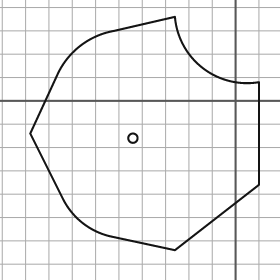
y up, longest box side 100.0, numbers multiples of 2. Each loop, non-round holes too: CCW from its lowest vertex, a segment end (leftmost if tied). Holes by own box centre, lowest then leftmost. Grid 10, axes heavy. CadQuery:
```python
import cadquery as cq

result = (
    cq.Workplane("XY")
    .moveTo(-26.0, -64.0)
    .lineTo(10.0, -36.0)
    .lineTo(10.0, 8.0)
    .threePointArc((-14.0, 14.0), (-26.0, 36.0))
    .lineTo(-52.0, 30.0)
    .threePointArc((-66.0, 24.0), (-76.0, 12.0))
    .lineTo(-88.0, -14.0)
    .lineTo(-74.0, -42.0)
    .threePointArc((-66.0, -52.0), (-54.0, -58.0))
    .close()
    .moveTo(-44.0, -16.0)
    .circle(2.0)
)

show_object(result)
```